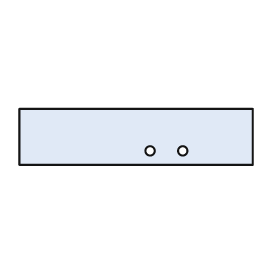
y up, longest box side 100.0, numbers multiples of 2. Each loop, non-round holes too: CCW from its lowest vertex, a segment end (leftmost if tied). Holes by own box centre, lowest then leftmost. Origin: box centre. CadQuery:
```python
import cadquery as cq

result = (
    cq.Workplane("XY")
    .moveTo(-50.0, -12.0)
    .lineTo(50.0, -12.0)
    .lineTo(50.0, 12.0)
    .lineTo(-50.0, 12.0)
    .close()
    .moveTo(6.0, -6.0)
    .circle(2.0)
    .moveTo(20.0, -6.0)
    .circle(2.0)
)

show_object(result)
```